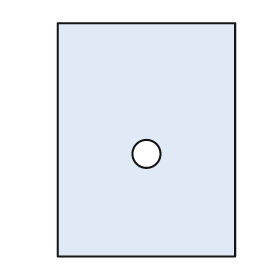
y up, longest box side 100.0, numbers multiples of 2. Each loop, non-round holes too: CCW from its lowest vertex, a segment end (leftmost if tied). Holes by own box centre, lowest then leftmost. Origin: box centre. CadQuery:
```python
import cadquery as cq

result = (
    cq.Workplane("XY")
    .moveTo(-38.0, -50.0)
    .lineTo(38.0, -50.0)
    .lineTo(38.0, 50.0)
    .lineTo(-38.0, 50.0)
    .close()
    .moveTo(0.0, -6.0)
    .circle(6.0)
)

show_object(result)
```